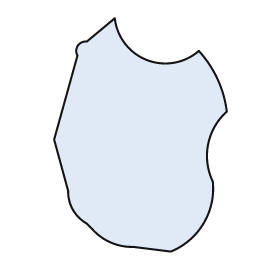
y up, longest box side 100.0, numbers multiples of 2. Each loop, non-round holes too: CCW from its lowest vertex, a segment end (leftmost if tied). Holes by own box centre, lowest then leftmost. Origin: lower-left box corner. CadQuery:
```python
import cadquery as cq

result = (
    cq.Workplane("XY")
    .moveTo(50.0, 0.0)
    .threePointArc((64.0, 12.0), (68.0, 30.0))
    .threePointArc((66.0, 46.0), (74.0, 60.0))
    .threePointArc((70.0, 74.0), (62.0, 86.0))
    .threePointArc((40.0, 82.0), (26.0, 100.0))
    .lineTo(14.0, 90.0)
    .threePointArc((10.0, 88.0), (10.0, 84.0))
    .lineTo(0.0, 48.0)
    .lineTo(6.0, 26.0)
    .threePointArc((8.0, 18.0), (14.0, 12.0))
    .lineTo(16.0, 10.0)
    .threePointArc((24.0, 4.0), (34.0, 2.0))
    .close()
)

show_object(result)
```